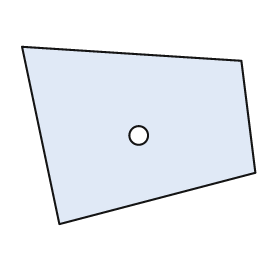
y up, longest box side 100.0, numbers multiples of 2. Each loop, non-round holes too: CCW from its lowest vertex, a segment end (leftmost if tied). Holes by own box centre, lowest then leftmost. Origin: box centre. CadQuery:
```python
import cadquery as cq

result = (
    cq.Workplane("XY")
    .moveTo(-34.0, -38.0)
    .lineTo(50.0, -16.0)
    .lineTo(44.0, 32.0)
    .lineTo(-50.0, 38.0)
    .close()
    .moveTo(0.0, 0.0)
    .circle(4.0)
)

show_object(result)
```